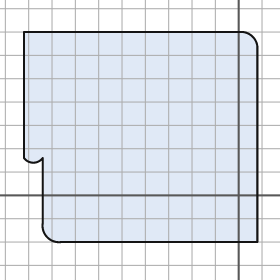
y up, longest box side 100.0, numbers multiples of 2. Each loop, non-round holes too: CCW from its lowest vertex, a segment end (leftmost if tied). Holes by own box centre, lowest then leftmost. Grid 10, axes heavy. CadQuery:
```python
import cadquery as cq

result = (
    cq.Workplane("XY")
    .moveTo(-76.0, -20.0)
    .lineTo(8.0, -20.0)
    .lineTo(8.0, 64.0)
    .threePointArc((6.0, 68.0), (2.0, 70.0))
    .lineTo(-92.0, 70.0)
    .lineTo(-92.0, 16.0)
    .threePointArc((-88.0, 14.0), (-84.0, 16.0))
    .lineTo(-84.0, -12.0)
    .threePointArc((-82.0, -18.0), (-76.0, -20.0))
    .close()
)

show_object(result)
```